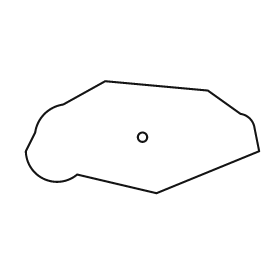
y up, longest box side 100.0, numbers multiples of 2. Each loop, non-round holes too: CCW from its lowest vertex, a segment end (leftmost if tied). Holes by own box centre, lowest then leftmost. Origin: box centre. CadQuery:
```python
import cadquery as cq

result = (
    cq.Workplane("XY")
    .moveTo(6.0, -24.0)
    .lineTo(50.0, -6.0)
    .lineTo(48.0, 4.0)
    .threePointArc((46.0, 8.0), (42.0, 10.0))
    .lineTo(28.0, 20.0)
    .lineTo(-16.0, 24.0)
    .lineTo(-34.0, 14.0)
    .threePointArc((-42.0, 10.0), (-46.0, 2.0))
    .lineTo(-50.0, -6.0)
    .threePointArc((-42.0, -18.0), (-28.0, -16.0))
    .close()
    .moveTo(0.0, 0.0)
    .circle(2.0)
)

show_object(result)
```